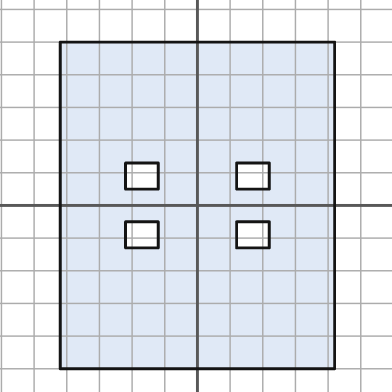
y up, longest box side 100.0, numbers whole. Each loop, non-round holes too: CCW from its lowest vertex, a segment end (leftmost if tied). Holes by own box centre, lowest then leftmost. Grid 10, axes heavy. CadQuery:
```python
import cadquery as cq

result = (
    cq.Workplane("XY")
    .moveTo(-42.0, -50.0)
    .lineTo(42.0, -50.0)
    .lineTo(42.0, 50.0)
    .lineTo(-42.0, 50.0)
    .close()
    .moveTo(-22.0, -13.0)
    .lineTo(-12.0, -13.0)
    .lineTo(-12.0, -5.0)
    .lineTo(-22.0, -5.0)
    .close()
    .moveTo(12.0, -13.0)
    .lineTo(22.0, -13.0)
    .lineTo(22.0, -5.0)
    .lineTo(12.0, -5.0)
    .close()
    .moveTo(-22.0, 5.0)
    .lineTo(-12.0, 5.0)
    .lineTo(-12.0, 13.0)
    .lineTo(-22.0, 13.0)
    .close()
    .moveTo(12.0, 5.0)
    .lineTo(22.0, 5.0)
    .lineTo(22.0, 13.0)
    .lineTo(12.0, 13.0)
    .close()
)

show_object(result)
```